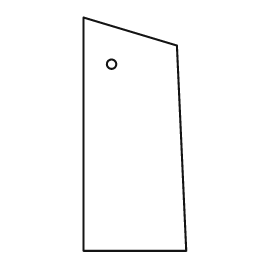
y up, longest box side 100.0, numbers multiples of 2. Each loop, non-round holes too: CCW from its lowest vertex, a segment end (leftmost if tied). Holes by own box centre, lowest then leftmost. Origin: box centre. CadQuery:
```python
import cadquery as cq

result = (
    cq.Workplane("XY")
    .moveTo(-22.0, -50.0)
    .lineTo(22.0, -50.0)
    .lineTo(18.0, 38.0)
    .lineTo(-22.0, 50.0)
    .close()
    .moveTo(-10.0, 30.0)
    .circle(2.0)
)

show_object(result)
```